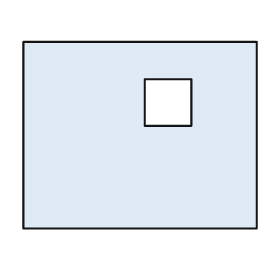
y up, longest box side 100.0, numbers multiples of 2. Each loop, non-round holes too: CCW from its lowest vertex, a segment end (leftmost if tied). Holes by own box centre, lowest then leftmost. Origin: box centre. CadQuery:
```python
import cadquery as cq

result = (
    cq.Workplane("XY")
    .moveTo(-50.0, -40.0)
    .lineTo(50.0, -40.0)
    .lineTo(50.0, 40.0)
    .lineTo(-50.0, 40.0)
    .close()
    .moveTo(2.0, 4.0)
    .lineTo(22.0, 4.0)
    .lineTo(22.0, 24.0)
    .lineTo(2.0, 24.0)
    .close()
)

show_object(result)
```